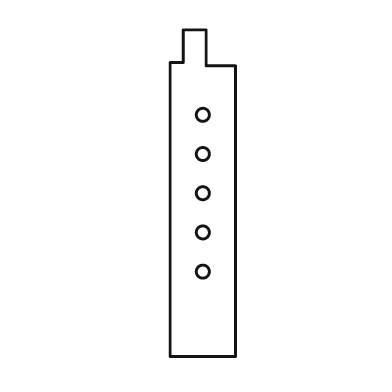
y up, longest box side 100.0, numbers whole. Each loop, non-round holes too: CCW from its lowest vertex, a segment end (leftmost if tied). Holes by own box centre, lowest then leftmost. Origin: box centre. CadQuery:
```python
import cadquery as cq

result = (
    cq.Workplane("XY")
    .moveTo(-10.0, -50.0)
    .lineTo(10.0, -50.0)
    .lineTo(10.0, 39.0)
    .lineTo(1.0, 39.0)
    .lineTo(1.0, 50.0)
    .lineTo(-6.0, 50.0)
    .lineTo(-6.0, 40.0)
    .lineTo(-10.0, 40.0)
    .close()
    .moveTo(0.0, -24.0)
    .circle(2.0)
    .moveTo(0.0, -12.0)
    .circle(2.0)
    .moveTo(0.0, 0.0)
    .circle(2.0)
    .moveTo(0.0, 12.0)
    .circle(2.0)
    .moveTo(0.0, 24.0)
    .circle(2.0)
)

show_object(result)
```